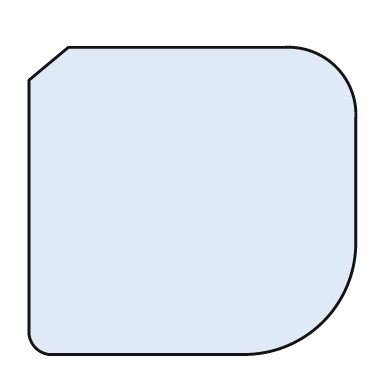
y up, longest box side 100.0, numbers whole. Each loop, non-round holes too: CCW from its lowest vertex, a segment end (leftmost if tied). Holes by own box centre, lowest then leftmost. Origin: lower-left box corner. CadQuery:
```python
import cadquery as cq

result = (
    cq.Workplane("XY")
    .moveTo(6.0, 0.0)
    .lineTo(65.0, 0.0)
    .threePointArc((90.0, 10.0), (100.0, 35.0))
    .lineTo(100.0, 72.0)
    .threePointArc((94.0, 88.0), (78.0, 94.0))
    .lineTo(12.0, 94.0)
    .lineTo(0.0, 84.0)
    .lineTo(0.0, 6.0)
    .threePointArc((2.0, 2.0), (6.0, 0.0))
    .close()
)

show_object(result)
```